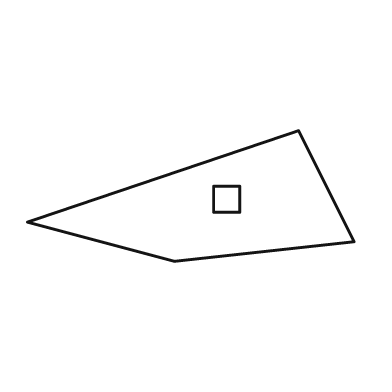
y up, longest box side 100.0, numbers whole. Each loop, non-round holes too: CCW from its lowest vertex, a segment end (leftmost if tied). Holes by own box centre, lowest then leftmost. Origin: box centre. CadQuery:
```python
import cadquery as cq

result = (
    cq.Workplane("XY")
    .moveTo(-5.0, -20.0)
    .lineTo(50.0, -14.0)
    .lineTo(33.0, 20.0)
    .lineTo(-50.0, -8.0)
    .close()
    .moveTo(7.0, -5.0)
    .lineTo(15.0, -5.0)
    .lineTo(15.0, 3.0)
    .lineTo(7.0, 3.0)
    .close()
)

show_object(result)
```